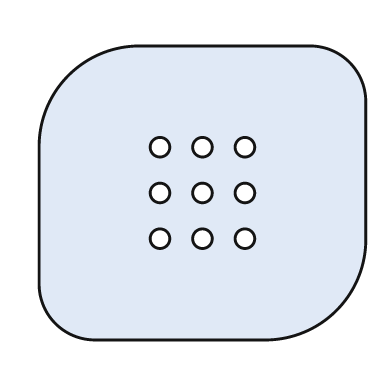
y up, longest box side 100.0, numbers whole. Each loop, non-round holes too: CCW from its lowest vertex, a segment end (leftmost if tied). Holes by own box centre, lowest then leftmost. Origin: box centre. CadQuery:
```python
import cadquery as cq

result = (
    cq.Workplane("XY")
    .moveTo(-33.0, -45.0)
    .lineTo(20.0, -45.0)
    .threePointArc((41.0, -36.0), (50.0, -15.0))
    .lineTo(50.0, 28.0)
    .threePointArc((45.0, 40.0), (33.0, 45.0))
    .lineTo(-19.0, 45.0)
    .threePointArc((-41.0, 36.0), (-50.0, 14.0))
    .lineTo(-50.0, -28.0)
    .threePointArc((-45.0, -40.0), (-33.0, -45.0))
    .close()
    .moveTo(-13.0, -14.0)
    .circle(3.0)
    .moveTo(0.0, -14.0)
    .circle(3.0)
    .moveTo(13.0, -14.0)
    .circle(3.0)
    .moveTo(-13.0, 0.0)
    .circle(3.0)
    .moveTo(0.0, 0.0)
    .circle(3.0)
    .moveTo(13.0, 0.0)
    .circle(3.0)
    .moveTo(-13.0, 14.0)
    .circle(3.0)
    .moveTo(0.0, 14.0)
    .circle(3.0)
    .moveTo(13.0, 14.0)
    .circle(3.0)
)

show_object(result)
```